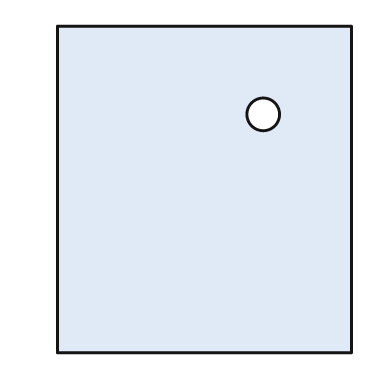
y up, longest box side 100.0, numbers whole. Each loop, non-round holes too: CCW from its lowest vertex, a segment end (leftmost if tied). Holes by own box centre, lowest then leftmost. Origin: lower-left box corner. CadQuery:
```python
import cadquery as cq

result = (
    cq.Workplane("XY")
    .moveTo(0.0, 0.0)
    .lineTo(90.0, 0.0)
    .lineTo(90.0, 100.0)
    .lineTo(0.0, 100.0)
    .close()
    .moveTo(63.0, 73.0)
    .circle(5.0)
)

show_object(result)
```